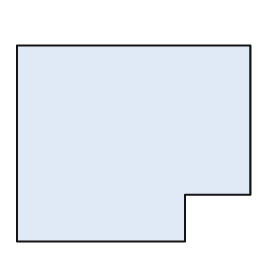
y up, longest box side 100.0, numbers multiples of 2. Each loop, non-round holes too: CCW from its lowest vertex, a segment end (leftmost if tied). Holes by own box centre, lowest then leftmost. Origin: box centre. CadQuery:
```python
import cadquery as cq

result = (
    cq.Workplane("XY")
    .moveTo(-50.0, -42.0)
    .lineTo(22.0, -42.0)
    .lineTo(22.0, -22.0)
    .lineTo(50.0, -22.0)
    .lineTo(50.0, 42.0)
    .lineTo(-50.0, 42.0)
    .close()
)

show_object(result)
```